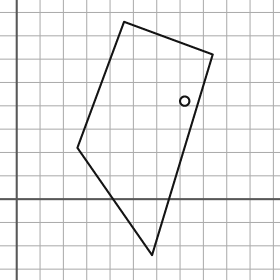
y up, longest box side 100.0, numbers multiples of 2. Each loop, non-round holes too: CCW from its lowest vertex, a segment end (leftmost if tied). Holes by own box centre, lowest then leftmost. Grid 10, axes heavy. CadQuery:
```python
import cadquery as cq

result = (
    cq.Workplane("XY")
    .moveTo(58.0, -24.0)
    .lineTo(84.0, 62.0)
    .lineTo(46.0, 76.0)
    .lineTo(26.0, 22.0)
    .close()
    .moveTo(72.0, 42.0)
    .circle(2.0)
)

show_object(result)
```